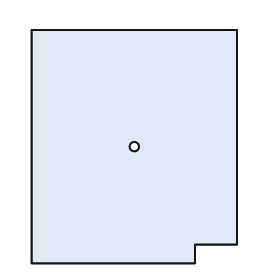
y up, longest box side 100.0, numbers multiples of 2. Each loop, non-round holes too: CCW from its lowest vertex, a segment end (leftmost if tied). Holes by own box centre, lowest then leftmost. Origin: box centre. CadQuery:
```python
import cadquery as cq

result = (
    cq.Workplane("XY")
    .moveTo(-44.0, -50.0)
    .lineTo(26.0, -50.0)
    .lineTo(26.0, -42.0)
    .lineTo(44.0, -42.0)
    .lineTo(44.0, 50.0)
    .lineTo(-44.0, 50.0)
    .close()
    .moveTo(0.0, 0.0)
    .circle(2.0)
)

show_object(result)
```